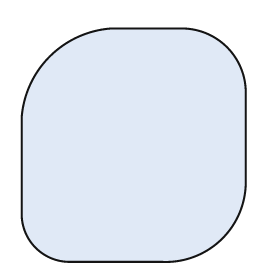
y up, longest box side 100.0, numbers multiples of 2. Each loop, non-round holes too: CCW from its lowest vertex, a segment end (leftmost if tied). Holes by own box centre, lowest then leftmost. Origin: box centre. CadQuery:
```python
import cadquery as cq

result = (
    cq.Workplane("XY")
    .moveTo(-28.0, -50.0)
    .lineTo(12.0, -50.0)
    .threePointArc((38.0, -40.0), (48.0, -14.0))
    .lineTo(48.0, 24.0)
    .threePointArc((40.0, 42.0), (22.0, 50.0))
    .lineTo(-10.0, 50.0)
    .threePointArc((-36.0, 38.0), (-48.0, 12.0))
    .lineTo(-48.0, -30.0)
    .threePointArc((-42.0, -44.0), (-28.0, -50.0))
    .close()
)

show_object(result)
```